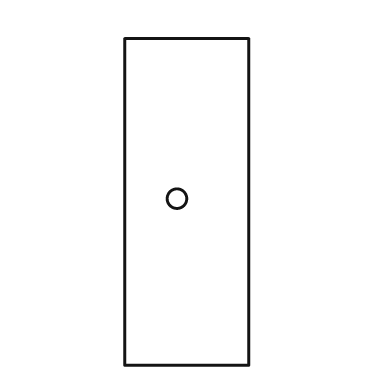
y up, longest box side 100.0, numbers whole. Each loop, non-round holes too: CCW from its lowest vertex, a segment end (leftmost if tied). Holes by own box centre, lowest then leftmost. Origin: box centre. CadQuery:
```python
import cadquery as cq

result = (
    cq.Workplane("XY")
    .moveTo(-19.0, -50.0)
    .lineTo(19.0, -50.0)
    .lineTo(19.0, 50.0)
    .lineTo(-19.0, 50.0)
    .close()
    .moveTo(-3.0, 1.0)
    .circle(3.0)
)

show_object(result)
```